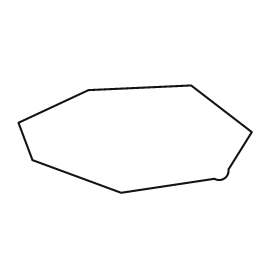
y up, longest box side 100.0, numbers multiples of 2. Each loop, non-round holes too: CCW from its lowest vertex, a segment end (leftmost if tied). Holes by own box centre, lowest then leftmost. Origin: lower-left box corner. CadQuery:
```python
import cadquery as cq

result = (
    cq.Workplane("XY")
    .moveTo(44.0, 0.0)
    .lineTo(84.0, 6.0)
    .threePointArc((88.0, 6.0), (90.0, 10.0))
    .lineTo(100.0, 26.0)
    .lineTo(74.0, 46.0)
    .lineTo(30.0, 44.0)
    .lineTo(0.0, 30.0)
    .lineTo(6.0, 14.0)
    .close()
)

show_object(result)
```